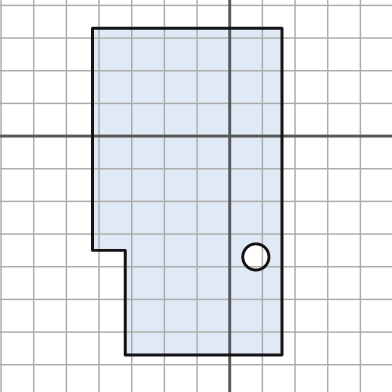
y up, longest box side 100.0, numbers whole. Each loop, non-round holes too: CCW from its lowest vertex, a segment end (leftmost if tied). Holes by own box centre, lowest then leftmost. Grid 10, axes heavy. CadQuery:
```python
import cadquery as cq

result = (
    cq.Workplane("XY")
    .moveTo(-32.0, -67.0)
    .lineTo(16.0, -67.0)
    .lineTo(16.0, 33.0)
    .lineTo(-42.0, 33.0)
    .lineTo(-42.0, -35.0)
    .lineTo(-32.0, -35.0)
    .close()
    .moveTo(8.0, -37.0)
    .circle(4.0)
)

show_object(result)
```